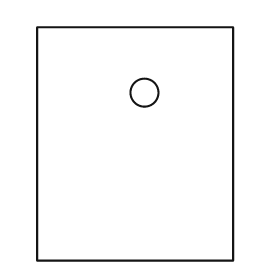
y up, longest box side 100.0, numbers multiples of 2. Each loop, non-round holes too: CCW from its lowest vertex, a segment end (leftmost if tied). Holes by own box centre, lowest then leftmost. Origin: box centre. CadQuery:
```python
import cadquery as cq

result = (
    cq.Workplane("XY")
    .moveTo(-42.0, -50.0)
    .lineTo(42.0, -50.0)
    .lineTo(42.0, 50.0)
    .lineTo(-42.0, 50.0)
    .close()
    .moveTo(4.0, 22.0)
    .circle(6.0)
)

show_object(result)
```